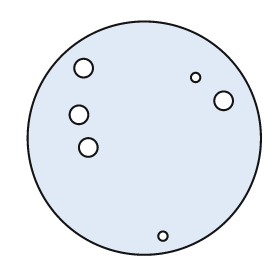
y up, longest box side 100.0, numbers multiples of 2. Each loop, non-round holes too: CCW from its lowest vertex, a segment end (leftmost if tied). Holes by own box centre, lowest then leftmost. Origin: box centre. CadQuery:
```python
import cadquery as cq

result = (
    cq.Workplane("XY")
    .moveTo(0.0, 0.0)
    .circle(50.0)
    .moveTo(8.0, -42.0)
    .circle(2.0)
    .moveTo(-24.0, -4.0)
    .circle(4.0)
    .moveTo(-28.0, 10.0)
    .circle(4.0)
    .moveTo(34.0, 16.0)
    .circle(4.0)
    .moveTo(22.0, 26.0)
    .circle(2.0)
    .moveTo(-26.0, 30.0)
    .circle(4.0)
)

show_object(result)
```